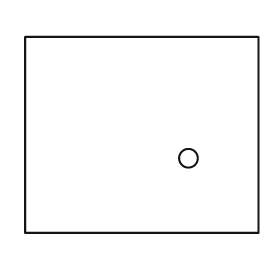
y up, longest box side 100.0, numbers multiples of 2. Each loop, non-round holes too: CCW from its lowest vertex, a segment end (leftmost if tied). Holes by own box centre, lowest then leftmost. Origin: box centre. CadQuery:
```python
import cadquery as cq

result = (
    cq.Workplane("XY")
    .moveTo(-50.0, -42.0)
    .lineTo(50.0, -42.0)
    .lineTo(50.0, 42.0)
    .lineTo(-50.0, 42.0)
    .close()
    .moveTo(20.0, -10.0)
    .circle(4.0)
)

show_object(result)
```